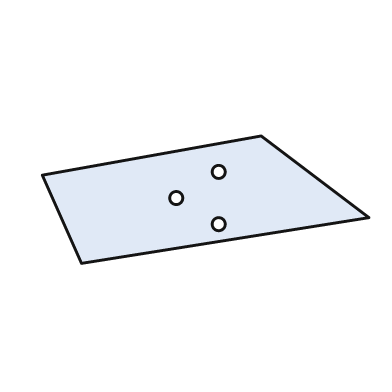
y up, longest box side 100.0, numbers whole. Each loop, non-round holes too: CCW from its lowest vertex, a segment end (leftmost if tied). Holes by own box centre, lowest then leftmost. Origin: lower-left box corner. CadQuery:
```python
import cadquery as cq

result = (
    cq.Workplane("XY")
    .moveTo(12.0, 0.0)
    .lineTo(100.0, 14.0)
    .lineTo(67.0, 39.0)
    .lineTo(0.0, 27.0)
    .close()
    .moveTo(54.0, 12.0)
    .circle(2.0)
    .moveTo(41.0, 20.0)
    .circle(2.0)
    .moveTo(54.0, 28.0)
    .circle(2.0)
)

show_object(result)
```